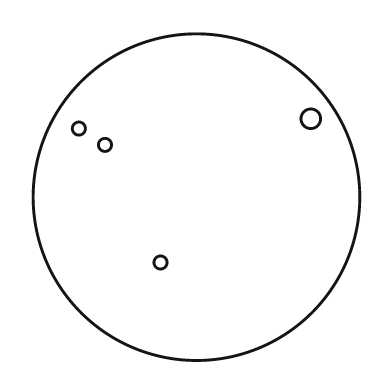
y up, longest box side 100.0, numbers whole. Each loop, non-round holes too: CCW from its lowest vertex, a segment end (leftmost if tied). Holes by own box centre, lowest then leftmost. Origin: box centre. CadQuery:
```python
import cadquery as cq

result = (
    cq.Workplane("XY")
    .moveTo(0.0, 0.0)
    .circle(50.0)
    .moveTo(-11.0, -20.0)
    .circle(2.0)
    .moveTo(-28.0, 16.0)
    .circle(2.0)
    .moveTo(-36.0, 21.0)
    .circle(2.0)
    .moveTo(35.0, 24.0)
    .circle(3.0)
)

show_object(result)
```